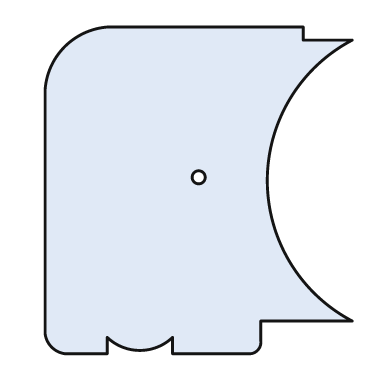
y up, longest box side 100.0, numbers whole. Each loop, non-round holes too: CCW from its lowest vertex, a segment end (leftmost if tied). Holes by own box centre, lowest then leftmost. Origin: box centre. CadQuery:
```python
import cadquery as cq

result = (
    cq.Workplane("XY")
    .moveTo(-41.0, -50.0)
    .lineTo(-28.0, -50.0)
    .lineTo(-28.0, -45.0)
    .threePointArc((-18.0, -49.0), (-8.0, -45.0))
    .lineTo(-8.0, -50.0)
    .lineTo(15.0, -50.0)
    .threePointArc((18.0, -49.0), (19.0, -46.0))
    .lineTo(19.0, -40.0)
    .lineTo(47.0, -40.0)
    .threePointArc((21.0, 3.0), (47.0, 46.0))
    .lineTo(32.0, 46.0)
    .lineTo(32.0, 50.0)
    .lineTo(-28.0, 50.0)
    .threePointArc((-41.0, 44.0), (-47.0, 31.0))
    .lineTo(-47.0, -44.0)
    .threePointArc((-45.0, -48.0), (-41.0, -50.0))
    .close()
    .moveTo(0.0, 4.0)
    .circle(2.0)
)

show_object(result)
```